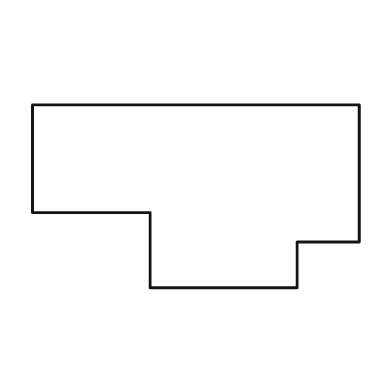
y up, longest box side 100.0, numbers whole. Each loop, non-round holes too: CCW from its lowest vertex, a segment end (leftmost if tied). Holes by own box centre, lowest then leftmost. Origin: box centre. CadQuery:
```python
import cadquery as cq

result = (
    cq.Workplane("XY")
    .moveTo(-14.0, -28.0)
    .lineTo(31.0, -28.0)
    .lineTo(31.0, -14.0)
    .lineTo(50.0, -14.0)
    .lineTo(50.0, 28.0)
    .lineTo(-50.0, 28.0)
    .lineTo(-50.0, -5.0)
    .lineTo(-14.0, -5.0)
    .close()
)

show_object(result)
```